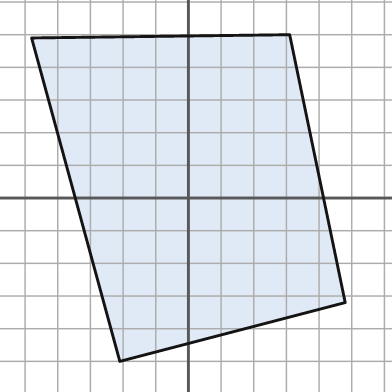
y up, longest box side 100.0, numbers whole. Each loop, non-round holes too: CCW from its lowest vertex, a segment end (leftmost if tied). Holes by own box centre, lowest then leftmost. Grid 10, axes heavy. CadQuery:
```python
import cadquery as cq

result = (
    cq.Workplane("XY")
    .moveTo(-21.0, -50.0)
    .lineTo(48.0, -32.0)
    .lineTo(31.0, 50.0)
    .lineTo(-48.0, 49.0)
    .close()
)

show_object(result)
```